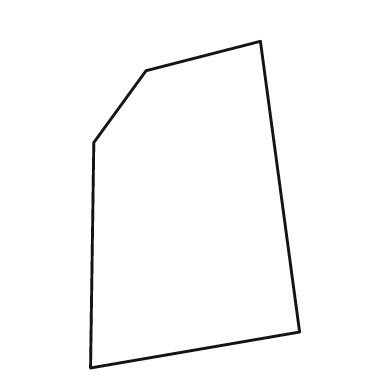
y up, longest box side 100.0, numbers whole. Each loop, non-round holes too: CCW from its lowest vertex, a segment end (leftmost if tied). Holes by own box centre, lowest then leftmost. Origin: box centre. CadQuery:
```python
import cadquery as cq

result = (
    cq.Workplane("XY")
    .moveTo(-32.0, -50.0)
    .lineTo(32.0, -39.0)
    .lineTo(20.0, 50.0)
    .lineTo(-15.0, 41.0)
    .lineTo(-31.0, 19.0)
    .close()
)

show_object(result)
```